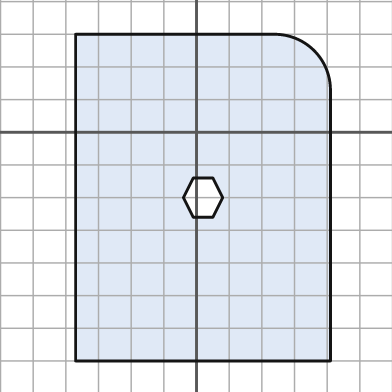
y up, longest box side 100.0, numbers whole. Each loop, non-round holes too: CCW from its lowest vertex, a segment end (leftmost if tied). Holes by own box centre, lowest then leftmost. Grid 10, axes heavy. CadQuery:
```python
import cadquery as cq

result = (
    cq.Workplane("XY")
    .moveTo(-37.0, -70.0)
    .lineTo(41.0, -70.0)
    .lineTo(41.0, 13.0)
    .threePointArc((36.0, 25.0), (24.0, 30.0))
    .lineTo(-37.0, 30.0)
    .close()
    .moveTo(-1.0, -26.0)
    .lineTo(5.0, -26.0)
    .lineTo(8.0, -20.0)
    .lineTo(5.0, -14.0)
    .lineTo(-1.0, -14.0)
    .lineTo(-4.0, -20.0)
    .close()
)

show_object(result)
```